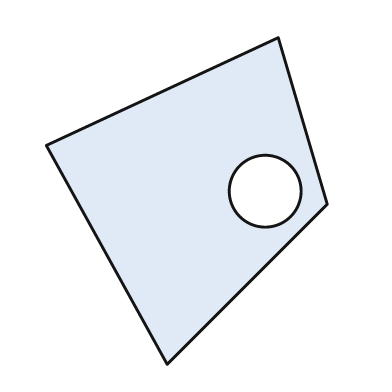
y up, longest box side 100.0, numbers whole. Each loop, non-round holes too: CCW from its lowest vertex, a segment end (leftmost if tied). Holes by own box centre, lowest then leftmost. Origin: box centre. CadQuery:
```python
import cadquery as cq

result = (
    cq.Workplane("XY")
    .moveTo(-6.0, -50.0)
    .lineTo(43.0, -1.0)
    .lineTo(28.0, 50.0)
    .lineTo(-43.0, 17.0)
    .close()
    .moveTo(24.0, 3.0)
    .circle(11.0)
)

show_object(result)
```